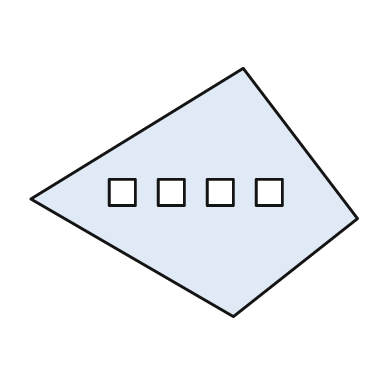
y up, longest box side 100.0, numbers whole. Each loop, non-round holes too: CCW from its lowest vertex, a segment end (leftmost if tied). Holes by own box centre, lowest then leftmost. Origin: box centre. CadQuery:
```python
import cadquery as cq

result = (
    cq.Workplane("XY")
    .moveTo(12.0, -38.0)
    .lineTo(50.0, -8.0)
    .lineTo(15.0, 38.0)
    .lineTo(-50.0, -2.0)
    .close()
    .moveTo(-26.0, -4.0)
    .lineTo(-18.0, -4.0)
    .lineTo(-18.0, 4.0)
    .lineTo(-26.0, 4.0)
    .close()
    .moveTo(-11.0, -4.0)
    .lineTo(-3.0, -4.0)
    .lineTo(-3.0, 4.0)
    .lineTo(-11.0, 4.0)
    .close()
    .moveTo(4.0, -4.0)
    .lineTo(12.0, -4.0)
    .lineTo(12.0, 4.0)
    .lineTo(4.0, 4.0)
    .close()
    .moveTo(19.0, -4.0)
    .lineTo(27.0, -4.0)
    .lineTo(27.0, 4.0)
    .lineTo(19.0, 4.0)
    .close()
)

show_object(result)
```